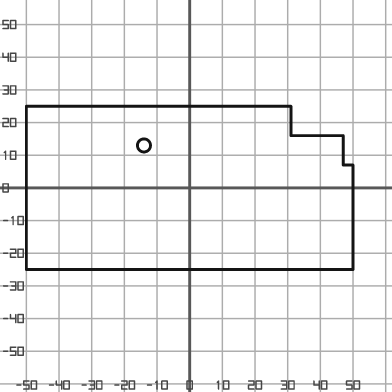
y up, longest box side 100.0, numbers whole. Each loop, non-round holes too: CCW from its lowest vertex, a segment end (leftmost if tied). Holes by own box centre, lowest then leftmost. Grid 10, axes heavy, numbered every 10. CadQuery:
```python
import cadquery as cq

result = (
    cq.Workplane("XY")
    .moveTo(-50.0, -25.0)
    .lineTo(50.0, -25.0)
    .lineTo(50.0, 7.0)
    .lineTo(47.0, 7.0)
    .lineTo(47.0, 16.0)
    .lineTo(31.0, 16.0)
    .lineTo(31.0, 25.0)
    .lineTo(-50.0, 25.0)
    .close()
    .moveTo(-14.0, 13.0)
    .circle(2.0)
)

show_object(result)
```